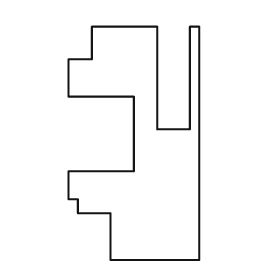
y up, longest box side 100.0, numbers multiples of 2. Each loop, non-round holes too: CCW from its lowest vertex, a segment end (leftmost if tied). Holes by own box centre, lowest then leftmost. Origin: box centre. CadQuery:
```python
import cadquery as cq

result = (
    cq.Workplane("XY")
    .moveTo(-10.0, -50.0)
    .lineTo(28.0, -50.0)
    .lineTo(28.0, 50.0)
    .lineTo(24.0, 50.0)
    .lineTo(24.0, 6.0)
    .lineTo(10.0, 6.0)
    .lineTo(10.0, 50.0)
    .lineTo(-18.0, 50.0)
    .lineTo(-18.0, 36.0)
    .lineTo(-28.0, 36.0)
    .lineTo(-28.0, 20.0)
    .lineTo(0.0, 20.0)
    .lineTo(0.0, -12.0)
    .lineTo(-28.0, -12.0)
    .lineTo(-28.0, -24.0)
    .lineTo(-24.0, -24.0)
    .lineTo(-24.0, -30.0)
    .lineTo(-10.0, -30.0)
    .close()
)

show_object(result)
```